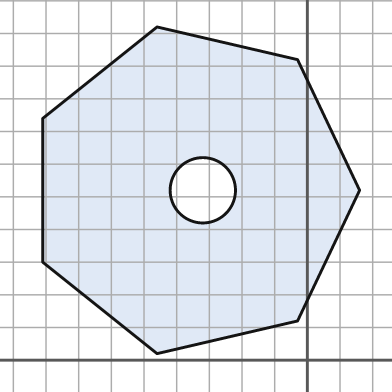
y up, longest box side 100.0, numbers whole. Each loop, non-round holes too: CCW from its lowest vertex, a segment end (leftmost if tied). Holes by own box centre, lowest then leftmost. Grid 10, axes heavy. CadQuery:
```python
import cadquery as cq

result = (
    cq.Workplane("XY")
    .moveTo(-46.0, 2.0)
    .lineTo(-3.0, 12.0)
    .lineTo(16.0, 52.0)
    .lineTo(-3.0, 92.0)
    .lineTo(-46.0, 102.0)
    .lineTo(-81.0, 74.0)
    .lineTo(-81.0, 30.0)
    .close()
    .moveTo(-32.0, 52.0)
    .circle(10.0)
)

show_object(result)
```